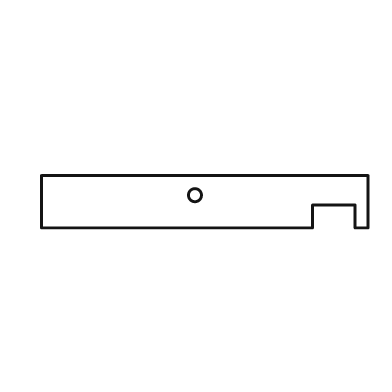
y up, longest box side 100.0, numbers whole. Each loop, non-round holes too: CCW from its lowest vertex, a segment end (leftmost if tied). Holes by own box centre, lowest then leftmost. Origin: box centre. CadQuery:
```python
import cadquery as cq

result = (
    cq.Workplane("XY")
    .moveTo(-50.0, -8.0)
    .lineTo(33.0, -8.0)
    .lineTo(33.0, -1.0)
    .lineTo(46.0, -1.0)
    .lineTo(46.0, -8.0)
    .lineTo(50.0, -8.0)
    .lineTo(50.0, 8.0)
    .lineTo(-50.0, 8.0)
    .close()
    .moveTo(-3.0, 2.0)
    .circle(2.0)
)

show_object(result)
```